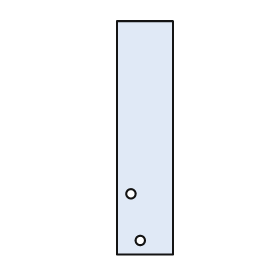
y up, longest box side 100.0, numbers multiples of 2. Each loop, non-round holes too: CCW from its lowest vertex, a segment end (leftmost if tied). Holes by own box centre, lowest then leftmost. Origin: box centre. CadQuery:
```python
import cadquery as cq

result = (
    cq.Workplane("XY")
    .moveTo(-12.0, -50.0)
    .lineTo(12.0, -50.0)
    .lineTo(12.0, 50.0)
    .lineTo(-12.0, 50.0)
    .close()
    .moveTo(-2.0, -44.0)
    .circle(2.0)
    .moveTo(-6.0, -24.0)
    .circle(2.0)
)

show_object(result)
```